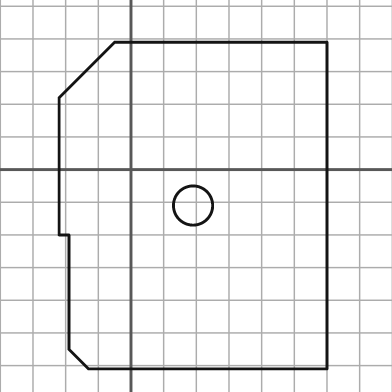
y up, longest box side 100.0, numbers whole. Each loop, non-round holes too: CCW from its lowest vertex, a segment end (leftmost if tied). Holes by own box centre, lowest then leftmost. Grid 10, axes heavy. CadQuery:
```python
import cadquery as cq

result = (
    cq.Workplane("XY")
    .moveTo(-13.0, -61.0)
    .lineTo(60.0, -61.0)
    .lineTo(60.0, 39.0)
    .lineTo(-5.0, 39.0)
    .lineTo(-22.0, 22.0)
    .lineTo(-22.0, -20.0)
    .lineTo(-19.0, -20.0)
    .lineTo(-19.0, -55.0)
    .close()
    .moveTo(19.0, -11.0)
    .circle(6.0)
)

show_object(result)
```